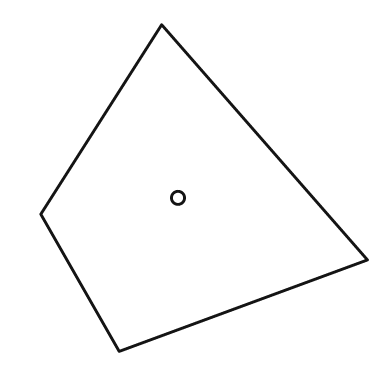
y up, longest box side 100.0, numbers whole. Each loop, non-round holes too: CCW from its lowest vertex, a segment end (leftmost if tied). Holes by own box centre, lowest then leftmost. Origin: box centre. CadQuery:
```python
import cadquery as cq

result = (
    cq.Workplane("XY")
    .moveTo(-26.0, -50.0)
    .lineTo(50.0, -22.0)
    .lineTo(-13.0, 50.0)
    .lineTo(-50.0, -8.0)
    .close()
    .moveTo(-8.0, -3.0)
    .circle(2.0)
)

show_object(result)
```